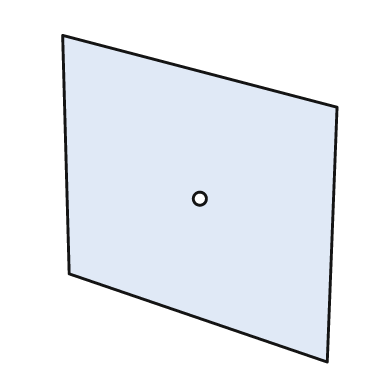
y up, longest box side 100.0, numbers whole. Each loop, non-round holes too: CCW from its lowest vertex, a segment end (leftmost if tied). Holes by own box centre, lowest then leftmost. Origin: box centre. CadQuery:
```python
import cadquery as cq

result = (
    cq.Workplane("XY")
    .moveTo(39.0, -50.0)
    .lineTo(42.0, 28.0)
    .lineTo(-42.0, 50.0)
    .lineTo(-40.0, -23.0)
    .close()
    .moveTo(0.0, 0.0)
    .circle(2.0)
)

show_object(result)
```